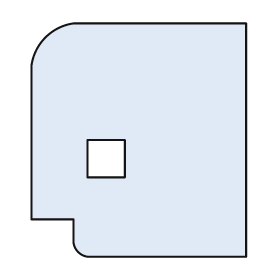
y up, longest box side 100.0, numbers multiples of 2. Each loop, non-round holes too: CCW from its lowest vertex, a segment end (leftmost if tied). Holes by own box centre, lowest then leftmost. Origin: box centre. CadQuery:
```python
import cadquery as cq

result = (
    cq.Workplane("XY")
    .moveTo(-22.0, -50.0)
    .lineTo(46.0, -50.0)
    .lineTo(46.0, 50.0)
    .lineTo(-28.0, 50.0)
    .threePointArc((-40.0, 44.0), (-46.0, 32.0))
    .lineTo(-46.0, -34.0)
    .lineTo(-28.0, -34.0)
    .lineTo(-28.0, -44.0)
    .threePointArc((-26.0, -48.0), (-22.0, -50.0))
    .close()
    .moveTo(-22.0, -16.0)
    .lineTo(-6.0, -16.0)
    .lineTo(-6.0, 0.0)
    .lineTo(-22.0, 0.0)
    .close()
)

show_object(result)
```